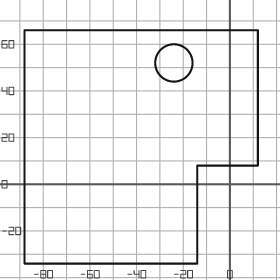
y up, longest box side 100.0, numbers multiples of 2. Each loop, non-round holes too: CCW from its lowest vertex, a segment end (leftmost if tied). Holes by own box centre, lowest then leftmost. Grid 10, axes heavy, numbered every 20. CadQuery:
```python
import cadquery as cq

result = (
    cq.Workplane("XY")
    .moveTo(-88.0, -34.0)
    .lineTo(-14.0, -34.0)
    .lineTo(-14.0, 8.0)
    .lineTo(12.0, 8.0)
    .lineTo(12.0, 66.0)
    .lineTo(-88.0, 66.0)
    .close()
    .moveTo(-24.0, 52.0)
    .circle(8.0)
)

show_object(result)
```